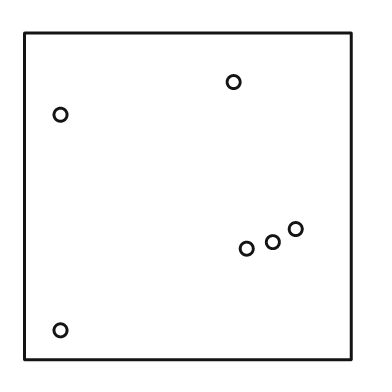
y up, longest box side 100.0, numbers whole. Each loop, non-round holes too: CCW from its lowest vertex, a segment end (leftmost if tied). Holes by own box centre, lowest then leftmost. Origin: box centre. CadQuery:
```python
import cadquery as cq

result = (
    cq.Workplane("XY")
    .moveTo(-50.0, -50.0)
    .lineTo(50.0, -50.0)
    .lineTo(50.0, 50.0)
    .lineTo(-50.0, 50.0)
    .close()
    .moveTo(-39.0, -41.0)
    .circle(2.0)
    .moveTo(18.0, -16.0)
    .circle(2.0)
    .moveTo(26.0, -14.0)
    .circle(2.0)
    .moveTo(33.0, -10.0)
    .circle(2.0)
    .moveTo(-39.0, 25.0)
    .circle(2.0)
    .moveTo(14.0, 35.0)
    .circle(2.0)
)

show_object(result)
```